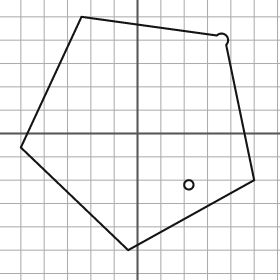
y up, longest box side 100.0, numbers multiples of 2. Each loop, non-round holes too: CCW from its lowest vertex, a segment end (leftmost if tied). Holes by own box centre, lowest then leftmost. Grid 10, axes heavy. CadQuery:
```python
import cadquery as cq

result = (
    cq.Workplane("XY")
    .moveTo(-4.0, -50.0)
    .lineTo(50.0, -20.0)
    .lineTo(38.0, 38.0)
    .threePointArc((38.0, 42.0), (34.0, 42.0))
    .lineTo(-24.0, 50.0)
    .lineTo(-50.0, -6.0)
    .close()
    .moveTo(22.0, -22.0)
    .circle(2.0)
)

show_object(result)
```